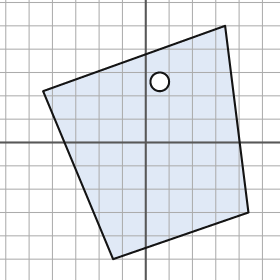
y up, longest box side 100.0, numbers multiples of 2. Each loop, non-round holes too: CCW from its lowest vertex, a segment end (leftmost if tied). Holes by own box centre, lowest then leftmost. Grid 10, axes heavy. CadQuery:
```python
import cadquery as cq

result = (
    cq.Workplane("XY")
    .moveTo(-14.0, -50.0)
    .lineTo(44.0, -30.0)
    .lineTo(34.0, 50.0)
    .lineTo(-44.0, 22.0)
    .close()
    .moveTo(6.0, 26.0)
    .circle(4.0)
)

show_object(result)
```